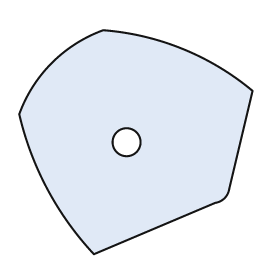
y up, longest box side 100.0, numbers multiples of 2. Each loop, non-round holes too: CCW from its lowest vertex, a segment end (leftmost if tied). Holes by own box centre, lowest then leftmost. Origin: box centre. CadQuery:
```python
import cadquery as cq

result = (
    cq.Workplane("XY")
    .moveTo(-18.0, -48.0)
    .lineTo(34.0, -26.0)
    .threePointArc((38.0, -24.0), (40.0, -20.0))
    .lineTo(50.0, 22.0)
    .threePointArc((20.0, 40.0), (-14.0, 48.0))
    .threePointArc((-36.0, 34.0), (-50.0, 12.0))
    .threePointArc((-38.0, -20.0), (-18.0, -48.0))
    .close()
    .moveTo(-4.0, 0.0)
    .circle(6.0)
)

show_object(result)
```